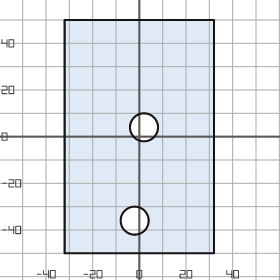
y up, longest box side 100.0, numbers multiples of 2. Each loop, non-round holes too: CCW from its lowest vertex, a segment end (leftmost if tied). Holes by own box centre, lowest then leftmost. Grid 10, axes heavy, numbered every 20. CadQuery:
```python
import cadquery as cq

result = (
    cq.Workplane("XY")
    .moveTo(-32.0, -50.0)
    .lineTo(32.0, -50.0)
    .lineTo(32.0, 50.0)
    .lineTo(-32.0, 50.0)
    .close()
    .moveTo(-2.0, -36.0)
    .circle(6.0)
    .moveTo(2.0, 4.0)
    .circle(6.0)
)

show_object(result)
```